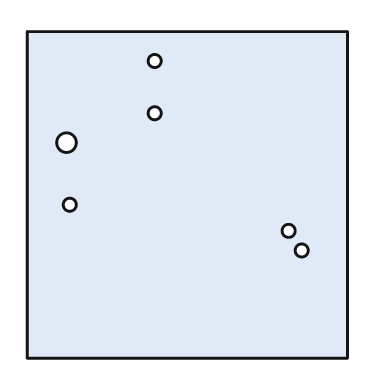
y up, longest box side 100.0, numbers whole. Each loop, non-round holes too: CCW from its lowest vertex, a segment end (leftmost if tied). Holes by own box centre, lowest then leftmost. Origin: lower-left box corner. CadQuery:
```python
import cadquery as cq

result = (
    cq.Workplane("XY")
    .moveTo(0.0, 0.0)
    .lineTo(98.0, 0.0)
    .lineTo(98.0, 100.0)
    .lineTo(0.0, 100.0)
    .close()
    .moveTo(84.0, 33.0)
    .circle(2.0)
    .moveTo(80.0, 39.0)
    .circle(2.0)
    .moveTo(13.0, 47.0)
    .circle(2.0)
    .moveTo(12.0, 66.0)
    .circle(3.0)
    .moveTo(39.0, 75.0)
    .circle(2.0)
    .moveTo(39.0, 91.0)
    .circle(2.0)
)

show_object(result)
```